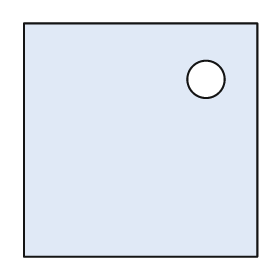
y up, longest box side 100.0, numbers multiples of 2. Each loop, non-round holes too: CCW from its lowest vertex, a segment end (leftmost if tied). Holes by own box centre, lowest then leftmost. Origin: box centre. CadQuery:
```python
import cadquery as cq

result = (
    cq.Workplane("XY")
    .moveTo(-50.0, -50.0)
    .lineTo(50.0, -50.0)
    .lineTo(50.0, 50.0)
    .lineTo(-50.0, 50.0)
    .close()
    .moveTo(28.0, 26.0)
    .circle(8.0)
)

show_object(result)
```